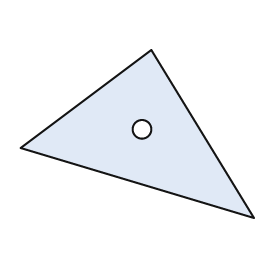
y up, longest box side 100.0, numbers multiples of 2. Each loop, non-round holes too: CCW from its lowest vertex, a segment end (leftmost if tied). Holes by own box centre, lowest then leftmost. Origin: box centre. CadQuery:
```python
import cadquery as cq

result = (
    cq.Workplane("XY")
    .moveTo(50.0, -36.0)
    .lineTo(6.0, 36.0)
    .lineTo(-50.0, -6.0)
    .close()
    .moveTo(2.0, 2.0)
    .circle(4.0)
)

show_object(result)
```